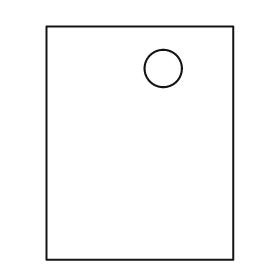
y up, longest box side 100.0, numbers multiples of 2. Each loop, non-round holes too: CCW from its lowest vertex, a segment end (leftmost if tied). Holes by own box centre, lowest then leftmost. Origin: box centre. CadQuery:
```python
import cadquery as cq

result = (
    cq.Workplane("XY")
    .moveTo(-40.0, -50.0)
    .lineTo(40.0, -50.0)
    .lineTo(40.0, 50.0)
    .lineTo(-40.0, 50.0)
    .close()
    .moveTo(10.0, 32.0)
    .circle(8.0)
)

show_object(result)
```